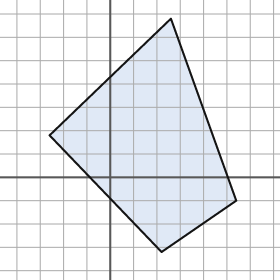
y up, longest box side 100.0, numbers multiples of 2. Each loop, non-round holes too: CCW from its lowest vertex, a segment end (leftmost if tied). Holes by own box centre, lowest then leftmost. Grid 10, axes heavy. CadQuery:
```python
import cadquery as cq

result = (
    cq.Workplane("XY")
    .moveTo(22.0, -32.0)
    .lineTo(54.0, -10.0)
    .lineTo(26.0, 68.0)
    .lineTo(-26.0, 18.0)
    .close()
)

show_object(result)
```